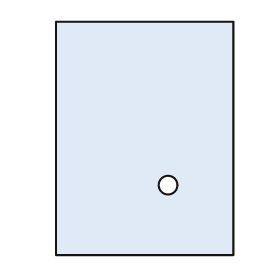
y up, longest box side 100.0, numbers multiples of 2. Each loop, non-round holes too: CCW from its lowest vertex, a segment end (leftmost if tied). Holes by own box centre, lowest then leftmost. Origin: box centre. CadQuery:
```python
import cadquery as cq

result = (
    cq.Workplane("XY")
    .moveTo(-38.0, -50.0)
    .lineTo(38.0, -50.0)
    .lineTo(38.0, 50.0)
    .lineTo(-38.0, 50.0)
    .close()
    .moveTo(10.0, -20.0)
    .circle(4.0)
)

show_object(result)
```